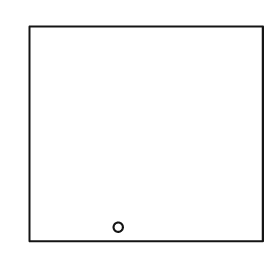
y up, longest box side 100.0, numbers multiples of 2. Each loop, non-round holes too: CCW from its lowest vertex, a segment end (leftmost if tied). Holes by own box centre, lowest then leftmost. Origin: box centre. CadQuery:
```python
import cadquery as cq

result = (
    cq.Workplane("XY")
    .moveTo(-50.0, -46.0)
    .lineTo(50.0, -46.0)
    .lineTo(50.0, 46.0)
    .lineTo(-50.0, 46.0)
    .close()
    .moveTo(-12.0, -40.0)
    .circle(2.0)
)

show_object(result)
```